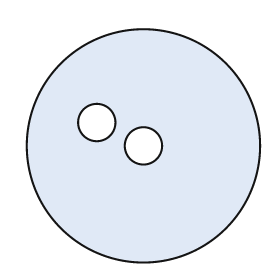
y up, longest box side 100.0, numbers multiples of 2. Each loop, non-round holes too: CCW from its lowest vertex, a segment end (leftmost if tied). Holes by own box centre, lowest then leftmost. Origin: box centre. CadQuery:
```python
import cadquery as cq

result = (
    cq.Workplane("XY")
    .moveTo(0.0, 0.0)
    .circle(50.0)
    .moveTo(0.0, 0.0)
    .circle(8.0)
    .moveTo(-20.0, 10.0)
    .circle(8.0)
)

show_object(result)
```